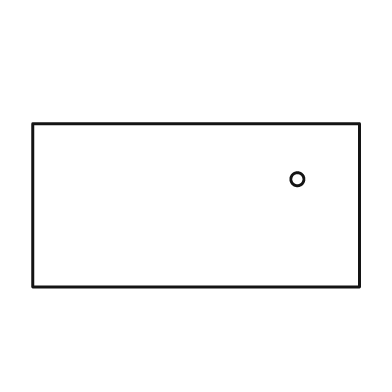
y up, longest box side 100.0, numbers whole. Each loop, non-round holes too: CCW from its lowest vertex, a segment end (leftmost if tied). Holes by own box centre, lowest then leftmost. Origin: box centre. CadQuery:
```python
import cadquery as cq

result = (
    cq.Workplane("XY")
    .moveTo(-50.0, -25.0)
    .lineTo(50.0, -25.0)
    .lineTo(50.0, 25.0)
    .lineTo(-50.0, 25.0)
    .close()
    .moveTo(31.0, 8.0)
    .circle(2.0)
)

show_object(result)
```